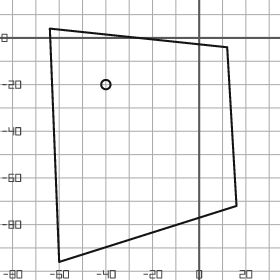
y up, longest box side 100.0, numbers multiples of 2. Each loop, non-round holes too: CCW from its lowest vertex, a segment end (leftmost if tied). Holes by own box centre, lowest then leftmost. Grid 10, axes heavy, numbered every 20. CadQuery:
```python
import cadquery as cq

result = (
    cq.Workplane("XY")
    .moveTo(-60.0, -96.0)
    .lineTo(16.0, -72.0)
    .lineTo(12.0, -4.0)
    .lineTo(-64.0, 4.0)
    .close()
    .moveTo(-40.0, -20.0)
    .circle(2.0)
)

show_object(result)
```